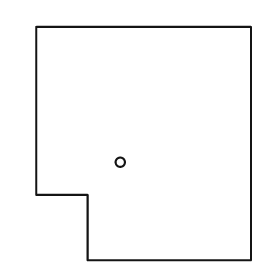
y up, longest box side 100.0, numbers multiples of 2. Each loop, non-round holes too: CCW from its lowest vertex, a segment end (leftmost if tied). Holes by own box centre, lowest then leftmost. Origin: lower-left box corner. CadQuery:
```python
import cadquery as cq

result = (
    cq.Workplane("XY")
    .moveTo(22.0, 0.0)
    .lineTo(92.0, 0.0)
    .lineTo(92.0, 100.0)
    .lineTo(0.0, 100.0)
    .lineTo(0.0, 28.0)
    .lineTo(22.0, 28.0)
    .close()
    .moveTo(36.0, 42.0)
    .circle(2.0)
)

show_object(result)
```